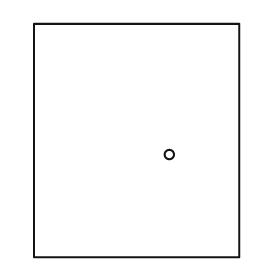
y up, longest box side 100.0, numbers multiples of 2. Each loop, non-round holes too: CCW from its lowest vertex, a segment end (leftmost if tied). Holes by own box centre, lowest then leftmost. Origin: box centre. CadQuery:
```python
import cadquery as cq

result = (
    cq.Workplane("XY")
    .moveTo(-44.0, -50.0)
    .lineTo(44.0, -50.0)
    .lineTo(44.0, 50.0)
    .lineTo(-44.0, 50.0)
    .close()
    .moveTo(14.0, -6.0)
    .circle(2.0)
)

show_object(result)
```